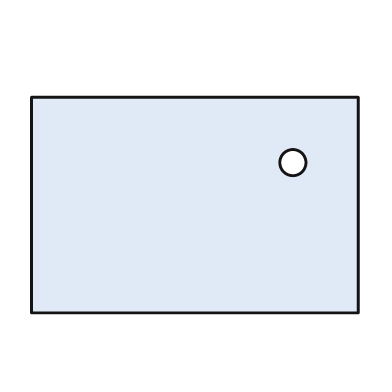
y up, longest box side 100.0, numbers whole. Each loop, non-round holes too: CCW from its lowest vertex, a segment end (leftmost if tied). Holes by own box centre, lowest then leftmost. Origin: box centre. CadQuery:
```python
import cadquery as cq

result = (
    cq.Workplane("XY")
    .moveTo(-50.0, -33.0)
    .lineTo(50.0, -33.0)
    .lineTo(50.0, 33.0)
    .lineTo(-50.0, 33.0)
    .close()
    .moveTo(30.0, 13.0)
    .circle(4.0)
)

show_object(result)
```